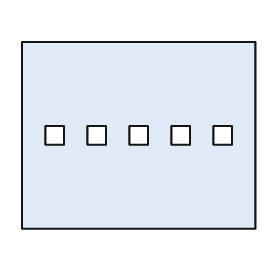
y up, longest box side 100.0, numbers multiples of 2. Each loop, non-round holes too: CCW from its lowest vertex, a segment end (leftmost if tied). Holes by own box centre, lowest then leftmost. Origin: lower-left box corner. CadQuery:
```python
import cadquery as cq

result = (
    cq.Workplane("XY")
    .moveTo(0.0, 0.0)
    .lineTo(100.0, 0.0)
    .lineTo(100.0, 80.0)
    .lineTo(0.0, 80.0)
    .close()
    .moveTo(10.0, 36.0)
    .lineTo(18.0, 36.0)
    .lineTo(18.0, 44.0)
    .lineTo(10.0, 44.0)
    .close()
    .moveTo(28.0, 36.0)
    .lineTo(36.0, 36.0)
    .lineTo(36.0, 44.0)
    .lineTo(28.0, 44.0)
    .close()
    .moveTo(46.0, 36.0)
    .lineTo(54.0, 36.0)
    .lineTo(54.0, 44.0)
    .lineTo(46.0, 44.0)
    .close()
    .moveTo(64.0, 36.0)
    .lineTo(72.0, 36.0)
    .lineTo(72.0, 44.0)
    .lineTo(64.0, 44.0)
    .close()
    .moveTo(82.0, 36.0)
    .lineTo(90.0, 36.0)
    .lineTo(90.0, 44.0)
    .lineTo(82.0, 44.0)
    .close()
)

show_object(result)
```